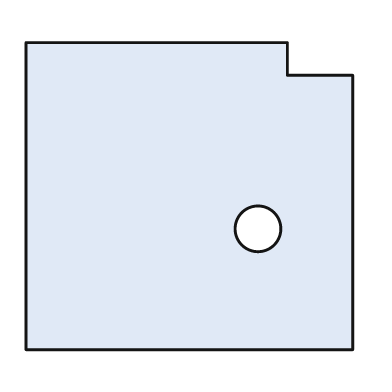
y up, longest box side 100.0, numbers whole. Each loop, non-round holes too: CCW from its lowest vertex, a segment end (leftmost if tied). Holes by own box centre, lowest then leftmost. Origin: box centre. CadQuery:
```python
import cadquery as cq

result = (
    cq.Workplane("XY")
    .moveTo(-50.0, -47.0)
    .lineTo(50.0, -47.0)
    .lineTo(50.0, 37.0)
    .lineTo(30.0, 37.0)
    .lineTo(30.0, 47.0)
    .lineTo(-50.0, 47.0)
    .close()
    .moveTo(21.0, -10.0)
    .circle(7.0)
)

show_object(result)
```